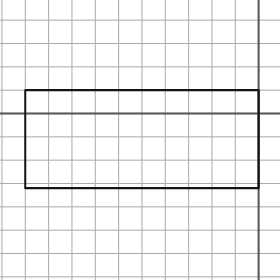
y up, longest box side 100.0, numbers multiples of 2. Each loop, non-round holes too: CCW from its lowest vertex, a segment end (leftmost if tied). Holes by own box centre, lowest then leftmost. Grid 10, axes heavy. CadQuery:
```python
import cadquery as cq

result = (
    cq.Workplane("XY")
    .moveTo(-100.0, -32.0)
    .lineTo(0.0, -32.0)
    .lineTo(0.0, 10.0)
    .lineTo(-100.0, 10.0)
    .close()
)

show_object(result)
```